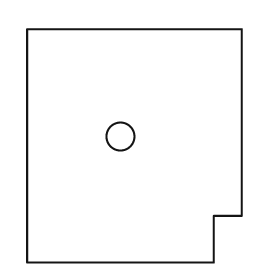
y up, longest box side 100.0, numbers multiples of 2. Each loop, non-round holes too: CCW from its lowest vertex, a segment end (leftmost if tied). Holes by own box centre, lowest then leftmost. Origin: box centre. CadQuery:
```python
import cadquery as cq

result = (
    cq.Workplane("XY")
    .moveTo(-46.0, -50.0)
    .lineTo(34.0, -50.0)
    .lineTo(34.0, -30.0)
    .lineTo(46.0, -30.0)
    .lineTo(46.0, 50.0)
    .lineTo(-46.0, 50.0)
    .close()
    .moveTo(-6.0, 4.0)
    .circle(6.0)
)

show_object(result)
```